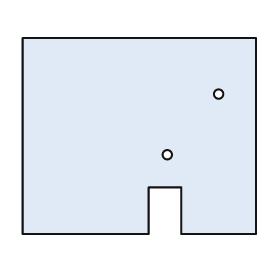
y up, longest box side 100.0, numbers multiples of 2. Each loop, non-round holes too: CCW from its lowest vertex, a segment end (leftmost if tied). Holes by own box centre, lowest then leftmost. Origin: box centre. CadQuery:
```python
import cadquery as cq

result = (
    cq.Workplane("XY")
    .moveTo(-50.0, -42.0)
    .lineTo(4.0, -42.0)
    .lineTo(4.0, -22.0)
    .lineTo(18.0, -22.0)
    .lineTo(18.0, -42.0)
    .lineTo(50.0, -42.0)
    .lineTo(50.0, 42.0)
    .lineTo(-50.0, 42.0)
    .close()
    .moveTo(12.0, -8.0)
    .circle(2.0)
    .moveTo(34.0, 18.0)
    .circle(2.0)
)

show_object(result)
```